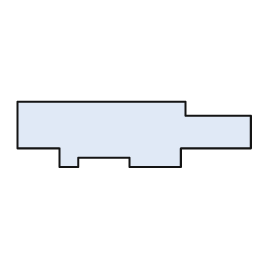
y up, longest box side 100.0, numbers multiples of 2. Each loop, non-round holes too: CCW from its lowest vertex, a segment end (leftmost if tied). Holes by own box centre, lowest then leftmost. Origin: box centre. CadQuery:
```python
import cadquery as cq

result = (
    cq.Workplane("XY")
    .moveTo(-32.0, -14.0)
    .lineTo(-24.0, -14.0)
    .lineTo(-24.0, -10.0)
    .lineTo(-2.0, -10.0)
    .lineTo(-2.0, -14.0)
    .lineTo(20.0, -14.0)
    .lineTo(20.0, -6.0)
    .lineTo(50.0, -6.0)
    .lineTo(50.0, 8.0)
    .lineTo(22.0, 8.0)
    .lineTo(22.0, 14.0)
    .lineTo(-50.0, 14.0)
    .lineTo(-50.0, -6.0)
    .lineTo(-32.0, -6.0)
    .close()
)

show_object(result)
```